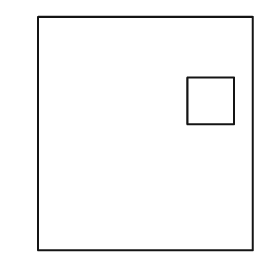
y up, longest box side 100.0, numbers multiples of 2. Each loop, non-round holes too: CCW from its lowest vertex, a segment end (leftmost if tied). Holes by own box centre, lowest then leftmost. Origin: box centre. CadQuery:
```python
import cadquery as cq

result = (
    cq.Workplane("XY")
    .moveTo(-46.0, -50.0)
    .lineTo(46.0, -50.0)
    .lineTo(46.0, 50.0)
    .lineTo(-46.0, 50.0)
    .close()
    .moveTo(18.0, 4.0)
    .lineTo(38.0, 4.0)
    .lineTo(38.0, 24.0)
    .lineTo(18.0, 24.0)
    .close()
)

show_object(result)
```